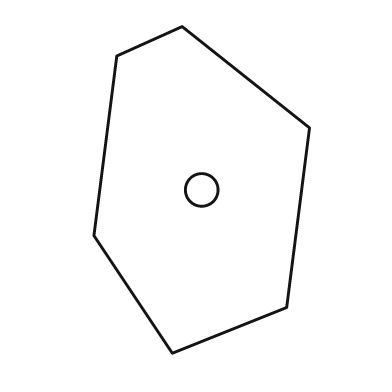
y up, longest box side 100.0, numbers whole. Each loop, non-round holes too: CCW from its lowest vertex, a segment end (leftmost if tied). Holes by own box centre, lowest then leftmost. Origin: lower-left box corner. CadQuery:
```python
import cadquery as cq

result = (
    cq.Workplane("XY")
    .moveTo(24.0, 0.0)
    .lineTo(59.0, 14.0)
    .lineTo(66.0, 69.0)
    .lineTo(27.0, 100.0)
    .lineTo(7.0, 91.0)
    .lineTo(0.0, 36.0)
    .close()
    .moveTo(33.0, 50.0)
    .circle(5.0)
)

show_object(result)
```